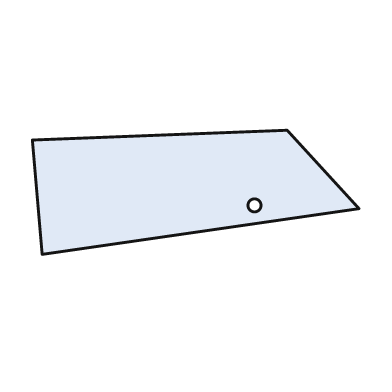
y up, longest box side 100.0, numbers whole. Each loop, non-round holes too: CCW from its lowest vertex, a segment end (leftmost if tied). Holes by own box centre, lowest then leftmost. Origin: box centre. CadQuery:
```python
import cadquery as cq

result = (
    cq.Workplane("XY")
    .moveTo(-47.0, -19.0)
    .lineTo(50.0, -5.0)
    .lineTo(28.0, 19.0)
    .lineTo(-50.0, 16.0)
    .close()
    .moveTo(18.0, -4.0)
    .circle(2.0)
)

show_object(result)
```